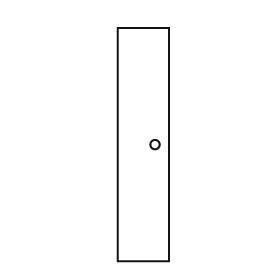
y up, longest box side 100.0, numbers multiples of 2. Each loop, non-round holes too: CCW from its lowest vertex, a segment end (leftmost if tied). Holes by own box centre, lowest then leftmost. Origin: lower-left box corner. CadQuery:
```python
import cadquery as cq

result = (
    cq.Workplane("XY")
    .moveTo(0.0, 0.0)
    .lineTo(22.0, 0.0)
    .lineTo(22.0, 100.0)
    .lineTo(0.0, 100.0)
    .close()
    .moveTo(16.0, 50.0)
    .circle(2.0)
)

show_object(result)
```